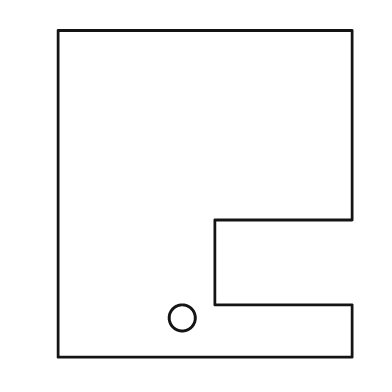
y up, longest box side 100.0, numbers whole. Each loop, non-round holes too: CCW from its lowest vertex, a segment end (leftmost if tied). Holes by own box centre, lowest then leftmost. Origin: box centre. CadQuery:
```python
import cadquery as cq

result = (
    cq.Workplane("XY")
    .moveTo(-45.0, -50.0)
    .lineTo(45.0, -50.0)
    .lineTo(45.0, -34.0)
    .lineTo(3.0, -34.0)
    .lineTo(3.0, -8.0)
    .lineTo(45.0, -8.0)
    .lineTo(45.0, 50.0)
    .lineTo(-45.0, 50.0)
    .close()
    .moveTo(-7.0, -38.0)
    .circle(4.0)
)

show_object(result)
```